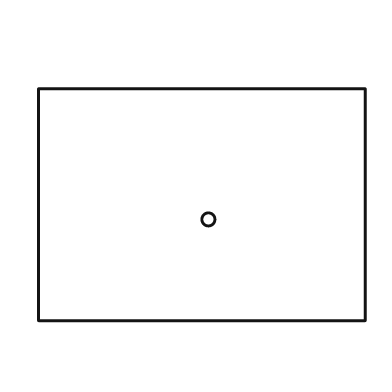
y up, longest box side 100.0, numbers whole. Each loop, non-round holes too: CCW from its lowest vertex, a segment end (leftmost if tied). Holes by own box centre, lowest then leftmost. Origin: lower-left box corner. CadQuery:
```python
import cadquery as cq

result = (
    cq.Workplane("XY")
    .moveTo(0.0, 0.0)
    .lineTo(100.0, 0.0)
    .lineTo(100.0, 71.0)
    .lineTo(0.0, 71.0)
    .close()
    .moveTo(52.0, 31.0)
    .circle(2.0)
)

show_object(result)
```